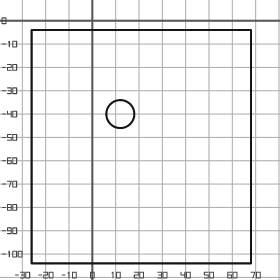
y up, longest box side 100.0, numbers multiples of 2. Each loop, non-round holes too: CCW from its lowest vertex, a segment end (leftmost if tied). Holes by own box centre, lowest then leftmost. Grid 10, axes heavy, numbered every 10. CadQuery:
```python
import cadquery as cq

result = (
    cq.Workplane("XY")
    .moveTo(-26.0, -104.0)
    .lineTo(68.0, -104.0)
    .lineTo(68.0, -4.0)
    .lineTo(-26.0, -4.0)
    .close()
    .moveTo(12.0, -40.0)
    .circle(6.0)
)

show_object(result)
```